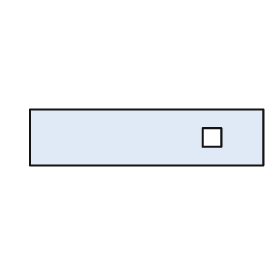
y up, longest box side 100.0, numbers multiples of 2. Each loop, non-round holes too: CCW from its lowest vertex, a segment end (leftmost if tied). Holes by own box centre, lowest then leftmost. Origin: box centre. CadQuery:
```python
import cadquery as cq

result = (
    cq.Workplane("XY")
    .moveTo(-50.0, -12.0)
    .lineTo(50.0, -12.0)
    .lineTo(50.0, 12.0)
    .lineTo(-50.0, 12.0)
    .close()
    .moveTo(24.0, -4.0)
    .lineTo(32.0, -4.0)
    .lineTo(32.0, 4.0)
    .lineTo(24.0, 4.0)
    .close()
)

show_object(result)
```